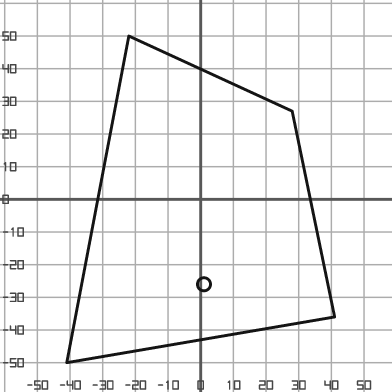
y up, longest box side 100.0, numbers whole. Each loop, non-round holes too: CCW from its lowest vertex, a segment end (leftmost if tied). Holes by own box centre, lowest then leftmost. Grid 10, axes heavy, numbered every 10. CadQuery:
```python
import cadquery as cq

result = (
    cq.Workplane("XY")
    .moveTo(-41.0, -50.0)
    .lineTo(41.0, -36.0)
    .lineTo(28.0, 27.0)
    .lineTo(-22.0, 50.0)
    .close()
    .moveTo(1.0, -26.0)
    .circle(2.0)
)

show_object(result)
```